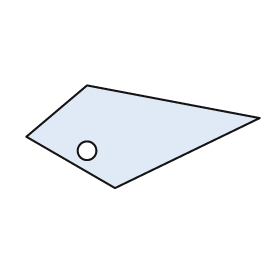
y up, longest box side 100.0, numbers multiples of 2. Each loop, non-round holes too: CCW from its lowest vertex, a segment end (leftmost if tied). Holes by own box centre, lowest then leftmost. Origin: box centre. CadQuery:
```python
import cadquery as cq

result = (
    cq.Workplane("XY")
    .moveTo(-12.0, -22.0)
    .lineTo(50.0, 8.0)
    .lineTo(-24.0, 22.0)
    .lineTo(-50.0, 0.0)
    .close()
    .moveTo(-24.0, -6.0)
    .circle(4.0)
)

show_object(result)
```